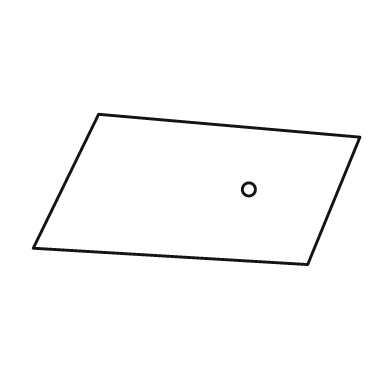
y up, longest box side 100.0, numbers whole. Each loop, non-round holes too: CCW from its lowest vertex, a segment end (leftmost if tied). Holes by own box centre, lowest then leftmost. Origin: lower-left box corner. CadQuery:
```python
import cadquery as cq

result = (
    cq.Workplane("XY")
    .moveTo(84.0, 0.0)
    .lineTo(100.0, 39.0)
    .lineTo(20.0, 46.0)
    .lineTo(0.0, 5.0)
    .close()
    .moveTo(66.0, 23.0)
    .circle(2.0)
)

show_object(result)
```